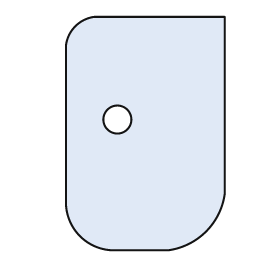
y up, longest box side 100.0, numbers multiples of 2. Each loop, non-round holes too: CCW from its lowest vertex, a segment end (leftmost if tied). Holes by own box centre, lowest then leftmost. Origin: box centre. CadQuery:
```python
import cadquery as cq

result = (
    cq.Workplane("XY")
    .moveTo(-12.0, -50.0)
    .lineTo(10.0, -50.0)
    .threePointArc((26.0, -42.0), (34.0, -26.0))
    .lineTo(34.0, 50.0)
    .lineTo(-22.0, 50.0)
    .threePointArc((-30.0, 46.0), (-34.0, 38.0))
    .lineTo(-34.0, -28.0)
    .threePointArc((-28.0, -44.0), (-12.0, -50.0))
    .close()
    .moveTo(-12.0, 6.0)
    .circle(6.0)
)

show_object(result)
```